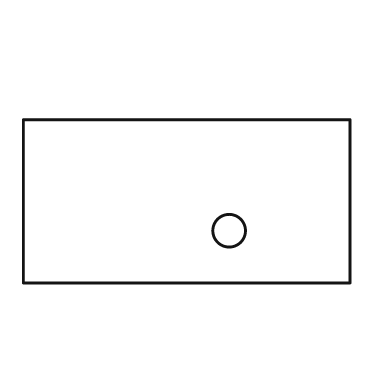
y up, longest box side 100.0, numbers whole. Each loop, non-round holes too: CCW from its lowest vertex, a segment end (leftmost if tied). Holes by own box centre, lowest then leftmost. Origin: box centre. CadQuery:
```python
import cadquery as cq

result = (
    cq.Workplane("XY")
    .moveTo(-50.0, -25.0)
    .lineTo(50.0, -25.0)
    .lineTo(50.0, 25.0)
    .lineTo(-50.0, 25.0)
    .close()
    .moveTo(13.0, -9.0)
    .circle(5.0)
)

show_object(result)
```